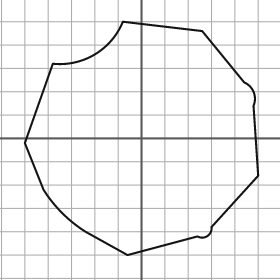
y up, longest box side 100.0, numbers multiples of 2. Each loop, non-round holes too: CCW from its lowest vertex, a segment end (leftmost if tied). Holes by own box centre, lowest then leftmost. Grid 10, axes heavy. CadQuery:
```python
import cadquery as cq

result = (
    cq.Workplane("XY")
    .moveTo(-6.0, -50.0)
    .lineTo(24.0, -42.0)
    .threePointArc((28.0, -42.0), (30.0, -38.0))
    .lineTo(50.0, -16.0)
    .lineTo(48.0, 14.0)
    .threePointArc((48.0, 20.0), (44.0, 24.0))
    .lineTo(26.0, 46.0)
    .lineTo(-8.0, 50.0)
    .threePointArc((-20.0, 36.0), (-38.0, 32.0))
    .lineTo(-50.0, -2.0)
    .lineTo(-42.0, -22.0)
    .threePointArc((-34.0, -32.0), (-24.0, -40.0))
    .close()
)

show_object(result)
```